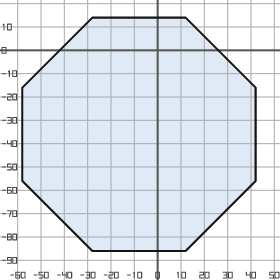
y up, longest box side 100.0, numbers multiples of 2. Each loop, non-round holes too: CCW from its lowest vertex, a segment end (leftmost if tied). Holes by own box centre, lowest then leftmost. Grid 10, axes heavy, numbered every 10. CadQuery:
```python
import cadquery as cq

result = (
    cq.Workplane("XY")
    .moveTo(-28.0, -86.0)
    .lineTo(12.0, -86.0)
    .lineTo(42.0, -56.0)
    .lineTo(42.0, -16.0)
    .lineTo(12.0, 14.0)
    .lineTo(-28.0, 14.0)
    .lineTo(-58.0, -16.0)
    .lineTo(-58.0, -56.0)
    .close()
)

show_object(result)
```